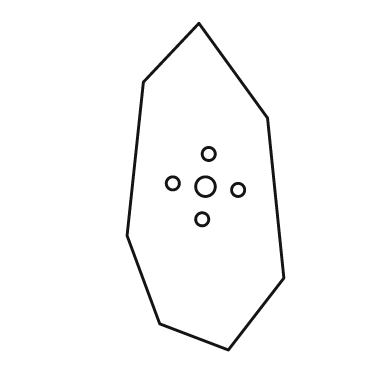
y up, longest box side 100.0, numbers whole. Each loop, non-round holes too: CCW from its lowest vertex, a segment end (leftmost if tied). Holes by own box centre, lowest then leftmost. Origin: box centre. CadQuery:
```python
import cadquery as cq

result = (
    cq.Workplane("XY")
    .moveTo(7.0, -50.0)
    .lineTo(24.0, -28.0)
    .lineTo(19.0, 21.0)
    .lineTo(-2.0, 50.0)
    .lineTo(-19.0, 32.0)
    .lineTo(-24.0, -15.0)
    .lineTo(-14.0, -42.0)
    .close()
    .moveTo(-1.0, -10.0)
    .circle(2.0)
    .moveTo(10.0, -1.0)
    .circle(2.0)
    .moveTo(0.0, 0.0)
    .circle(3.0)
    .moveTo(-10.0, 1.0)
    .circle(2.0)
    .moveTo(1.0, 10.0)
    .circle(2.0)
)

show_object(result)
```